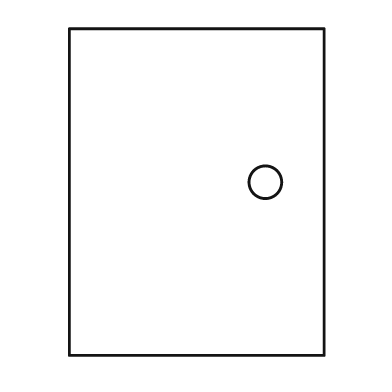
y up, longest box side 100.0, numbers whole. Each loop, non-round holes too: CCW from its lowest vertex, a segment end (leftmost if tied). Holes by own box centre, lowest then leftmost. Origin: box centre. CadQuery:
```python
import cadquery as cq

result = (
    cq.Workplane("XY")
    .moveTo(-39.0, -50.0)
    .lineTo(39.0, -50.0)
    .lineTo(39.0, 50.0)
    .lineTo(-39.0, 50.0)
    .close()
    .moveTo(21.0, 3.0)
    .circle(5.0)
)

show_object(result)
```